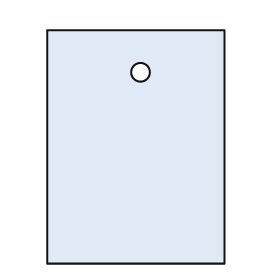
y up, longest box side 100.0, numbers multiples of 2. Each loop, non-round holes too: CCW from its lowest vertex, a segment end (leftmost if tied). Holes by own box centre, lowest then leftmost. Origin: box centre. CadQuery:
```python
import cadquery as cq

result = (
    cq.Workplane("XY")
    .moveTo(-38.0, -50.0)
    .lineTo(38.0, -50.0)
    .lineTo(38.0, 50.0)
    .lineTo(-38.0, 50.0)
    .close()
    .moveTo(2.0, 32.0)
    .circle(4.0)
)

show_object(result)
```